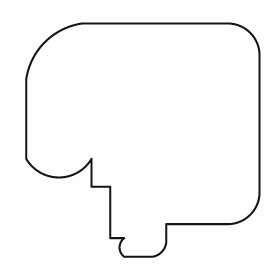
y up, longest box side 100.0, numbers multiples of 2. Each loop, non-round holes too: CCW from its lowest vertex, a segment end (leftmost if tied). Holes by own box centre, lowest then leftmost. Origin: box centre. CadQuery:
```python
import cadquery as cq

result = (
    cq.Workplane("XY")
    .moveTo(-8.0, -50.0)
    .lineTo(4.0, -50.0)
    .threePointArc((8.0, -48.0), (10.0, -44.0))
    .lineTo(10.0, -36.0)
    .lineTo(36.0, -36.0)
    .threePointArc((46.0, -32.0), (50.0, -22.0))
    .lineTo(50.0, 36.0)
    .threePointArc((46.0, 46.0), (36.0, 50.0))
    .lineTo(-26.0, 50.0)
    .threePointArc((-42.0, 42.0), (-50.0, 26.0))
    .lineTo(-50.0, -8.0)
    .threePointArc((-36.0, -16.0), (-22.0, -8.0))
    .lineTo(-22.0, -20.0)
    .lineTo(-14.0, -20.0)
    .lineTo(-14.0, -42.0)
    .lineTo(-8.0, -42.0)
    .threePointArc((-10.0, -46.0), (-8.0, -50.0))
    .close()
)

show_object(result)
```